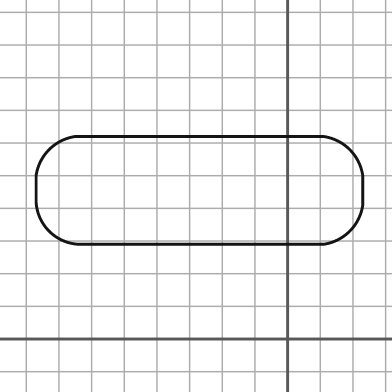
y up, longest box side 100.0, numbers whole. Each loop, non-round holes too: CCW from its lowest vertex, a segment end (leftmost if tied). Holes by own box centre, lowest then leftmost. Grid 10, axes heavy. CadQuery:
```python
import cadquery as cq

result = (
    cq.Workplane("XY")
    .moveTo(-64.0, 29.0)
    .lineTo(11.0, 29.0)
    .threePointArc((19.0, 33.0), (23.0, 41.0))
    .lineTo(23.0, 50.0)
    .threePointArc((19.0, 58.0), (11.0, 62.0))
    .lineTo(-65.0, 62.0)
    .threePointArc((-73.0, 58.0), (-77.0, 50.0))
    .lineTo(-77.0, 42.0)
    .threePointArc((-73.0, 33.0), (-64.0, 29.0))
    .close()
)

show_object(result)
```